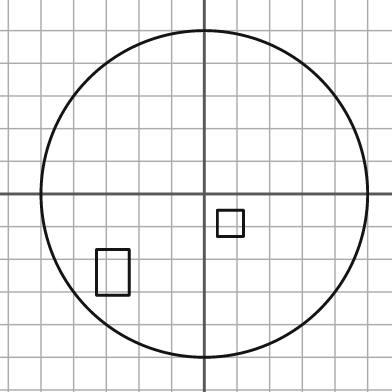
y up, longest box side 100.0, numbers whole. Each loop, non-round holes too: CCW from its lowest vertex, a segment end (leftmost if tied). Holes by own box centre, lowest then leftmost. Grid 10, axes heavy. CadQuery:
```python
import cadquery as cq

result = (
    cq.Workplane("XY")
    .moveTo(0.0, 0.0)
    .circle(50.0)
    .moveTo(-33.0, -31.0)
    .lineTo(-23.0, -31.0)
    .lineTo(-23.0, -17.0)
    .lineTo(-33.0, -17.0)
    .close()
    .moveTo(4.0, -13.0)
    .lineTo(12.0, -13.0)
    .lineTo(12.0, -5.0)
    .lineTo(4.0, -5.0)
    .close()
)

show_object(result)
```